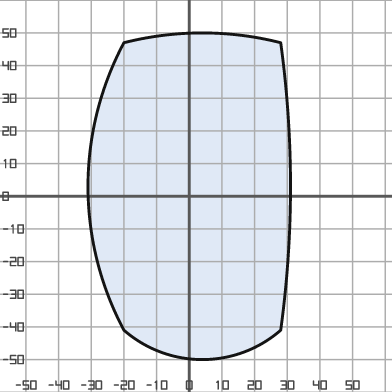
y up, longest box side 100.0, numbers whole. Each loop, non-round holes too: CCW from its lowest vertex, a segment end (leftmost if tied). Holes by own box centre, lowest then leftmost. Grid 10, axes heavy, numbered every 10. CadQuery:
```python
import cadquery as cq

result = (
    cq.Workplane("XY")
    .moveTo(-20.0, -41.0)
    .threePointArc((4.0, -50.0), (28.0, -41.0))
    .threePointArc((31.0, 3.0), (28.0, 47.0))
    .threePointArc((4.0, 50.0), (-20.0, 47.0))
    .threePointArc((-31.0, 3.0), (-20.0, -41.0))
    .close()
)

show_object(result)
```